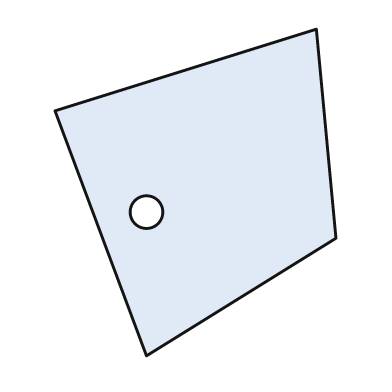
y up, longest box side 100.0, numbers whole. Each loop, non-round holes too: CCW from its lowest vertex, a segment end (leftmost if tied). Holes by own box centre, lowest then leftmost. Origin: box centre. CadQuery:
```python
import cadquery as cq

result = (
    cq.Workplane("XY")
    .moveTo(-15.0, -50.0)
    .lineTo(43.0, -14.0)
    .lineTo(37.0, 50.0)
    .lineTo(-43.0, 25.0)
    .close()
    .moveTo(-15.0, -6.0)
    .circle(5.0)
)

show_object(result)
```